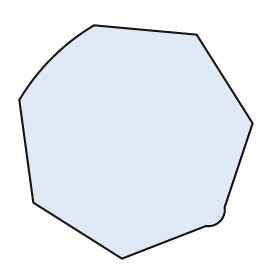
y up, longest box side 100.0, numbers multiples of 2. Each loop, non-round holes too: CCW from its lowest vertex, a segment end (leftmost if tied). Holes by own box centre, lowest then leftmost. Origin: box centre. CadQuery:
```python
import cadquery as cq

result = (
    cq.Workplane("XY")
    .moveTo(-6.0, -50.0)
    .lineTo(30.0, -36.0)
    .threePointArc((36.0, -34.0), (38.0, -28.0))
    .lineTo(50.0, 8.0)
    .lineTo(26.0, 46.0)
    .lineTo(-18.0, 50.0)
    .threePointArc((-36.0, 36.0), (-50.0, 18.0))
    .lineTo(-44.0, -26.0)
    .close()
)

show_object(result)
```